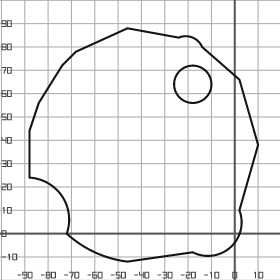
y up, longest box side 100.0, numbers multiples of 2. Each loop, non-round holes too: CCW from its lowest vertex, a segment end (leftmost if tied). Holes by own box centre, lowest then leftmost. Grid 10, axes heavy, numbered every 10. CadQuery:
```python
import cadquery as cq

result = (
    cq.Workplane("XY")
    .moveTo(-46.0, -12.0)
    .lineTo(-18.0, -8.0)
    .threePointArc((-2.0, -6.0), (2.0, 10.0))
    .lineTo(10.0, 38.0)
    .lineTo(2.0, 66.0)
    .lineTo(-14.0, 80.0)
    .threePointArc((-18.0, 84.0), (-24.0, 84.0))
    .lineTo(-46.0, 88.0)
    .lineTo(-68.0, 78.0)
    .lineTo(-74.0, 72.0)
    .lineTo(-84.0, 56.0)
    .lineTo(-88.0, 44.0)
    .lineTo(-88.0, 24.0)
    .threePointArc((-74.0, 16.0), (-72.0, 0.0))
    .threePointArc((-60.0, -8.0), (-46.0, -12.0))
    .close()
    .moveTo(-18.0, 64.0)
    .circle(8.0)
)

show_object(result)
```